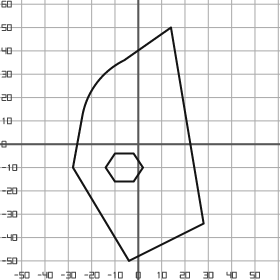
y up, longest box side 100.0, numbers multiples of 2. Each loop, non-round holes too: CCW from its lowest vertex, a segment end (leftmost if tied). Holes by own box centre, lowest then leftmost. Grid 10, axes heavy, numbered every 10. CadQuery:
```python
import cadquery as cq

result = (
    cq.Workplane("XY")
    .moveTo(-4.0, -50.0)
    .lineTo(28.0, -34.0)
    .lineTo(14.0, 50.0)
    .lineTo(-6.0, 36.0)
    .threePointArc((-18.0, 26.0), (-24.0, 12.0))
    .lineTo(-28.0, -10.0)
    .close()
    .moveTo(-10.0, -16.0)
    .lineTo(-2.0, -16.0)
    .lineTo(2.0, -10.0)
    .lineTo(-2.0, -4.0)
    .lineTo(-10.0, -4.0)
    .lineTo(-14.0, -10.0)
    .close()
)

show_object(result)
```